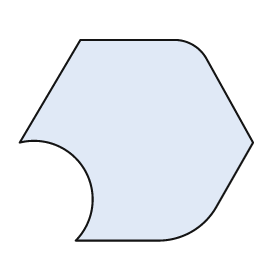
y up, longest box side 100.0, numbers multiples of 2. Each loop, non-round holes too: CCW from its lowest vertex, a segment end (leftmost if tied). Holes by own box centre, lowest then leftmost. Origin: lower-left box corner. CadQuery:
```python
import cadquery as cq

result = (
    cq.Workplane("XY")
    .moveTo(24.0, 0.0)
    .lineTo(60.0, 0.0)
    .threePointArc((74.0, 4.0), (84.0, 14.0))
    .lineTo(100.0, 42.0)
    .lineTo(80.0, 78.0)
    .threePointArc((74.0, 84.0), (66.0, 86.0))
    .lineTo(26.0, 86.0)
    .lineTo(0.0, 42.0)
    .threePointArc((28.0, 30.0), (24.0, 0.0))
    .close()
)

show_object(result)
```